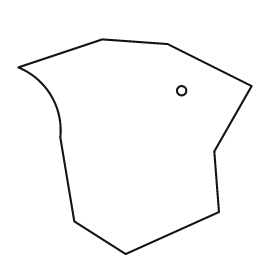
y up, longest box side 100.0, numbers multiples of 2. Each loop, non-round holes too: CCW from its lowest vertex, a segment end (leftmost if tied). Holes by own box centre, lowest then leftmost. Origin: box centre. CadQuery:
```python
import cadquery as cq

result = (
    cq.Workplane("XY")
    .moveTo(-4.0, -46.0)
    .lineTo(36.0, -28.0)
    .lineTo(34.0, -2.0)
    .lineTo(50.0, 26.0)
    .lineTo(14.0, 44.0)
    .lineTo(-14.0, 46.0)
    .lineTo(-50.0, 34.0)
    .threePointArc((-36.0, 22.0), (-32.0, 4.0))
    .lineTo(-26.0, -32.0)
    .close()
    .moveTo(20.0, 24.0)
    .circle(2.0)
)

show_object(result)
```